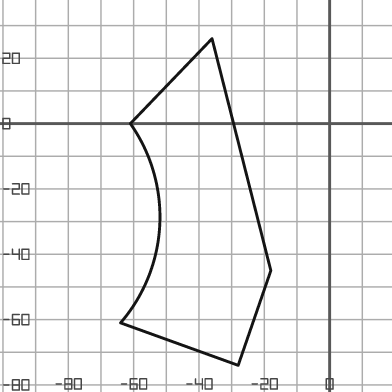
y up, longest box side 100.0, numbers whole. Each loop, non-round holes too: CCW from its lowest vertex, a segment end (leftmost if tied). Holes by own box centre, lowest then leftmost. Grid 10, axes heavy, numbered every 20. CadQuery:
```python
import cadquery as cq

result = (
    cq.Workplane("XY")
    .moveTo(-28.0, -74.0)
    .lineTo(-18.0, -45.0)
    .lineTo(-36.0, 26.0)
    .lineTo(-61.0, 0.0)
    .threePointArc((-52.0, -31.0), (-64.0, -61.0))
    .close()
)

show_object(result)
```